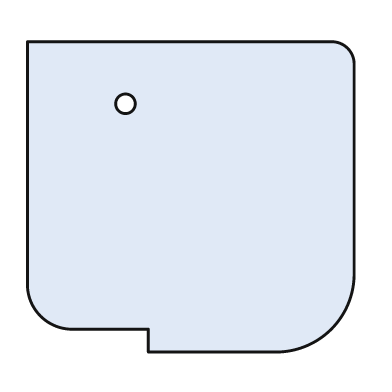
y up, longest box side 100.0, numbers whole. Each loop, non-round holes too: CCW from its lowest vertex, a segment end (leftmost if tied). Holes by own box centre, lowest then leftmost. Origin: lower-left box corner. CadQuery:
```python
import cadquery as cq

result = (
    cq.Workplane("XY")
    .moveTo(37.0, 0.0)
    .lineTo(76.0, 0.0)
    .threePointArc((93.0, 7.0), (100.0, 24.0))
    .lineTo(100.0, 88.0)
    .threePointArc((98.0, 93.0), (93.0, 95.0))
    .lineTo(0.0, 95.0)
    .lineTo(0.0, 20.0)
    .threePointArc((4.0, 11.0), (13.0, 7.0))
    .lineTo(37.0, 7.0)
    .close()
    .moveTo(30.0, 76.0)
    .circle(3.0)
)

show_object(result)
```